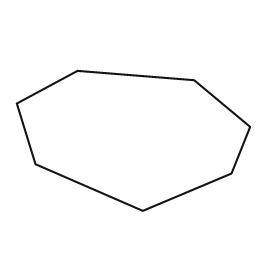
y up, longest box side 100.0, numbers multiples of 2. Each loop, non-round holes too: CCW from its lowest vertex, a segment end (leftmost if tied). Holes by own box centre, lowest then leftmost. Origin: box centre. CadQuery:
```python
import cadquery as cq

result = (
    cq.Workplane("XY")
    .moveTo(4.0, -30.0)
    .lineTo(42.0, -14.0)
    .lineTo(50.0, 6.0)
    .lineTo(26.0, 26.0)
    .lineTo(-24.0, 30.0)
    .lineTo(-50.0, 16.0)
    .lineTo(-42.0, -10.0)
    .close()
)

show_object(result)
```